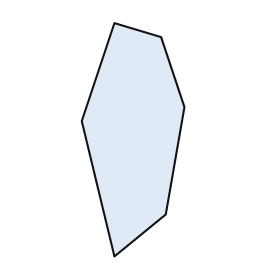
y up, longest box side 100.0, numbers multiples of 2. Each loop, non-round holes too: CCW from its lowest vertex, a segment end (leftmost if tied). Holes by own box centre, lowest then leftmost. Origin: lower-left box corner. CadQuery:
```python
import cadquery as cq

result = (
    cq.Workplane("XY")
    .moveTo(14.0, 0.0)
    .lineTo(36.0, 18.0)
    .lineTo(44.0, 64.0)
    .lineTo(34.0, 94.0)
    .lineTo(14.0, 100.0)
    .lineTo(0.0, 58.0)
    .close()
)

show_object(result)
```